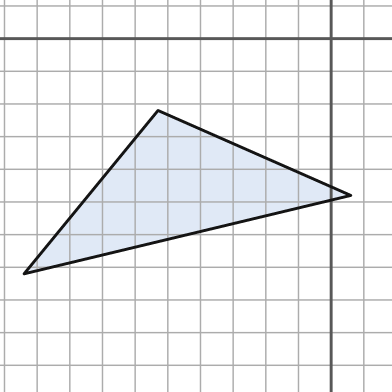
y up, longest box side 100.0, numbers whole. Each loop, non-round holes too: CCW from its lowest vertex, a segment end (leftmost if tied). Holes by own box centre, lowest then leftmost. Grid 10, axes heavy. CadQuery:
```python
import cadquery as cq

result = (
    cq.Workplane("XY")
    .moveTo(-94.0, -72.0)
    .lineTo(6.0, -48.0)
    .lineTo(-53.0, -22.0)
    .close()
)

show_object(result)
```